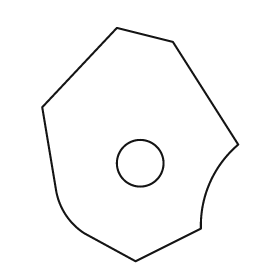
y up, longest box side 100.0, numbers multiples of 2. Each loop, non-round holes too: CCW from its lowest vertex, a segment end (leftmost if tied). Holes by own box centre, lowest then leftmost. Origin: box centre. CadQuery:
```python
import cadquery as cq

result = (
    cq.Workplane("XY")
    .moveTo(-2.0, -50.0)
    .lineTo(26.0, -36.0)
    .threePointArc((30.0, -16.0), (42.0, 0.0))
    .lineTo(14.0, 44.0)
    .lineTo(-10.0, 50.0)
    .lineTo(-42.0, 16.0)
    .lineTo(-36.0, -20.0)
    .threePointArc((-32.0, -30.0), (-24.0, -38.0))
    .close()
    .moveTo(0.0, -8.0)
    .circle(10.0)
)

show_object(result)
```